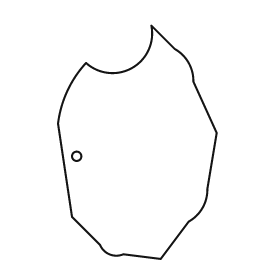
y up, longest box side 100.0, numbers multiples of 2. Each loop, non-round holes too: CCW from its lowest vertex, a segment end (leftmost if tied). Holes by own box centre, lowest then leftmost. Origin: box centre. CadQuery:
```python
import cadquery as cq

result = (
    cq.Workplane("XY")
    .moveTo(10.0, -50.0)
    .lineTo(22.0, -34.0)
    .threePointArc((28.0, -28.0), (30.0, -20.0))
    .lineTo(34.0, 4.0)
    .lineTo(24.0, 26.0)
    .threePointArc((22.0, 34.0), (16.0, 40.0))
    .lineTo(6.0, 50.0)
    .threePointArc((-2.0, 32.0), (-22.0, 34.0))
    .threePointArc((-30.0, 22.0), (-34.0, 8.0))
    .lineTo(-28.0, -32.0)
    .lineTo(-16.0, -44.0)
    .threePointArc((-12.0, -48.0), (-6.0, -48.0))
    .close()
    .moveTo(-26.0, -6.0)
    .circle(2.0)
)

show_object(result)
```